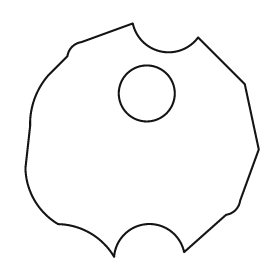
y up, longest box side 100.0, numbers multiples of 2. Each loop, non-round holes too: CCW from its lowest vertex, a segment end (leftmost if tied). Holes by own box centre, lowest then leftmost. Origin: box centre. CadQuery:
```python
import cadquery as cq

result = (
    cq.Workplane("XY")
    .moveTo(-12.0, -50.0)
    .threePointArc((2.0, -36.0), (18.0, -48.0))
    .lineTo(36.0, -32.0)
    .threePointArc((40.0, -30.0), (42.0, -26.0))
    .lineTo(50.0, -4.0)
    .lineTo(44.0, 24.0)
    .lineTo(24.0, 44.0)
    .threePointArc((8.0, 38.0), (-4.0, 50.0))
    .lineTo(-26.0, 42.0)
    .threePointArc((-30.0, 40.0), (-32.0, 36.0))
    .lineTo(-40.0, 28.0)
    .threePointArc((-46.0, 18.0), (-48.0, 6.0))
    .lineTo(-50.0, -12.0)
    .threePointArc((-46.0, -26.0), (-36.0, -36.0))
    .threePointArc((-22.0, -40.0), (-12.0, -50.0))
    .close()
    .moveTo(2.0, 20.0)
    .circle(12.0)
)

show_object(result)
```